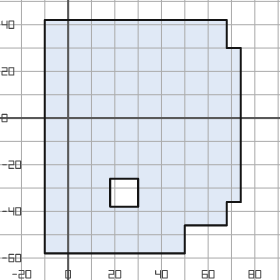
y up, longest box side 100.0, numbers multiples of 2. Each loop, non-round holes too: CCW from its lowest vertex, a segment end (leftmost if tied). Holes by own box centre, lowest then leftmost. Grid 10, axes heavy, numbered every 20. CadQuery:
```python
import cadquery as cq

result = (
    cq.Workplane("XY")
    .moveTo(-10.0, -58.0)
    .lineTo(50.0, -58.0)
    .lineTo(50.0, -46.0)
    .lineTo(68.0, -46.0)
    .lineTo(68.0, -36.0)
    .lineTo(74.0, -36.0)
    .lineTo(74.0, 30.0)
    .lineTo(68.0, 30.0)
    .lineTo(68.0, 42.0)
    .lineTo(-10.0, 42.0)
    .close()
    .moveTo(18.0, -38.0)
    .lineTo(30.0, -38.0)
    .lineTo(30.0, -26.0)
    .lineTo(18.0, -26.0)
    .close()
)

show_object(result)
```